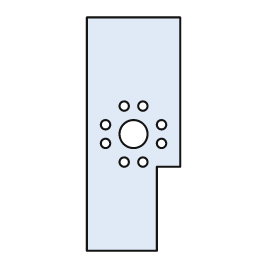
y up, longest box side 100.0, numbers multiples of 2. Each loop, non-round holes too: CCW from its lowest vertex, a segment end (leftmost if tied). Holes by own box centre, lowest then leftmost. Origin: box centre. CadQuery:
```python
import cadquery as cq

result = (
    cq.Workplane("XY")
    .moveTo(-20.0, -50.0)
    .lineTo(10.0, -50.0)
    .lineTo(10.0, -14.0)
    .lineTo(20.0, -14.0)
    .lineTo(20.0, 50.0)
    .lineTo(-20.0, 50.0)
    .close()
    .moveTo(-4.0, -12.0)
    .circle(2.0)
    .moveTo(4.0, -12.0)
    .circle(2.0)
    .moveTo(-12.0, -4.0)
    .circle(2.0)
    .moveTo(12.0, -4.0)
    .circle(2.0)
    .moveTo(0.0, 0.0)
    .circle(6.0)
    .moveTo(-12.0, 4.0)
    .circle(2.0)
    .moveTo(12.0, 4.0)
    .circle(2.0)
    .moveTo(-4.0, 12.0)
    .circle(2.0)
    .moveTo(4.0, 12.0)
    .circle(2.0)
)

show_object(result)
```